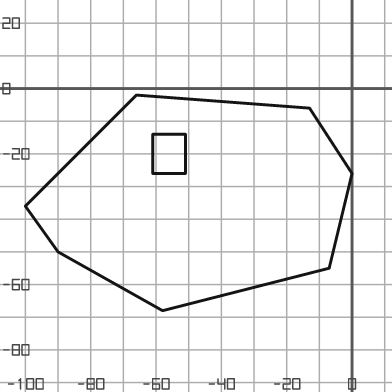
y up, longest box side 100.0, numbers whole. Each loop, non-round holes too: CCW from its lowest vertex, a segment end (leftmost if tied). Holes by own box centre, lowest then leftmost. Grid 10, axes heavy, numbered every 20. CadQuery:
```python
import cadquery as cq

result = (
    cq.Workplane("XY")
    .moveTo(-58.0, -68.0)
    .lineTo(-7.0, -55.0)
    .lineTo(0.0, -26.0)
    .lineTo(-13.0, -6.0)
    .lineTo(-66.0, -2.0)
    .lineTo(-100.0, -36.0)
    .lineTo(-90.0, -50.0)
    .close()
    .moveTo(-61.0, -26.0)
    .lineTo(-51.0, -26.0)
    .lineTo(-51.0, -14.0)
    .lineTo(-61.0, -14.0)
    .close()
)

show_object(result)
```